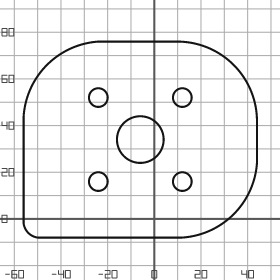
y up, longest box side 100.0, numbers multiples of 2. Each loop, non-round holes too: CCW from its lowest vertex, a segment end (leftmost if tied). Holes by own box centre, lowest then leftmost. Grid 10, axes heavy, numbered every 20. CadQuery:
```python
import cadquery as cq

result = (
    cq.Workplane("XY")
    .moveTo(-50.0, -8.0)
    .lineTo(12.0, -8.0)
    .threePointArc((34.0, 2.0), (44.0, 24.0))
    .lineTo(44.0, 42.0)
    .threePointArc((34.0, 66.0), (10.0, 76.0))
    .lineTo(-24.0, 76.0)
    .threePointArc((-46.0, 66.0), (-56.0, 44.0))
    .lineTo(-56.0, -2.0)
    .threePointArc((-54.0, -6.0), (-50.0, -8.0))
    .close()
    .moveTo(-24.0, 16.0)
    .circle(4.0)
    .moveTo(12.0, 16.0)
    .circle(4.0)
    .moveTo(-6.0, 34.0)
    .circle(10.0)
    .moveTo(-24.0, 52.0)
    .circle(4.0)
    .moveTo(12.0, 52.0)
    .circle(4.0)
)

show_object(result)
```